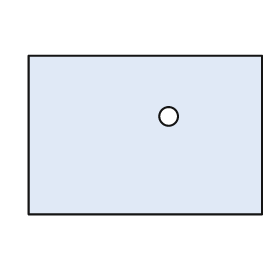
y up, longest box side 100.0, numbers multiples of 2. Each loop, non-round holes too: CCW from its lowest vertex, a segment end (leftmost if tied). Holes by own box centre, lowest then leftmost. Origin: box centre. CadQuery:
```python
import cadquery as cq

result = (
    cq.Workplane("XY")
    .moveTo(-50.0, -34.0)
    .lineTo(50.0, -34.0)
    .lineTo(50.0, 34.0)
    .lineTo(-50.0, 34.0)
    .close()
    .moveTo(10.0, 8.0)
    .circle(4.0)
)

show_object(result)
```